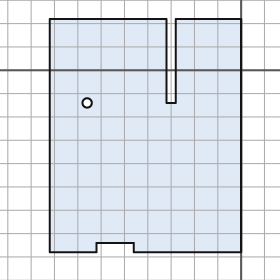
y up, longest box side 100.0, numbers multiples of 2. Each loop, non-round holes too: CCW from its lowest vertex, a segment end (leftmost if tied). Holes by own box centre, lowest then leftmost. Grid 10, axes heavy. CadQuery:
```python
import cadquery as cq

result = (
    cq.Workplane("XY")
    .moveTo(-82.0, -78.0)
    .lineTo(-62.0, -78.0)
    .lineTo(-62.0, -74.0)
    .lineTo(-46.0, -74.0)
    .lineTo(-46.0, -78.0)
    .lineTo(0.0, -78.0)
    .lineTo(0.0, 22.0)
    .lineTo(-28.0, 22.0)
    .lineTo(-28.0, -14.0)
    .lineTo(-32.0, -14.0)
    .lineTo(-32.0, 22.0)
    .lineTo(-82.0, 22.0)
    .close()
    .moveTo(-66.0, -14.0)
    .circle(2.0)
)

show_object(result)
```